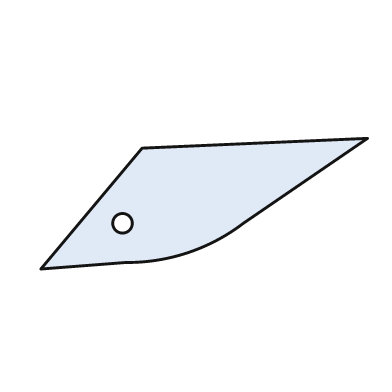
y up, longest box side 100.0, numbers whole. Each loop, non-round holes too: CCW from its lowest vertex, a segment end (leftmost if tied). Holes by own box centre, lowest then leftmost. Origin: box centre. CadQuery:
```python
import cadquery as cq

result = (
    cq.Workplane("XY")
    .moveTo(-50.0, -20.0)
    .lineTo(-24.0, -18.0)
    .threePointArc((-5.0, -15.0), (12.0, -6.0))
    .lineTo(50.0, 20.0)
    .lineTo(-19.0, 17.0)
    .close()
    .moveTo(-25.0, -6.0)
    .circle(3.0)
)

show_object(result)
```